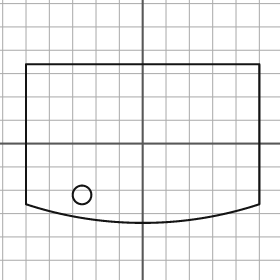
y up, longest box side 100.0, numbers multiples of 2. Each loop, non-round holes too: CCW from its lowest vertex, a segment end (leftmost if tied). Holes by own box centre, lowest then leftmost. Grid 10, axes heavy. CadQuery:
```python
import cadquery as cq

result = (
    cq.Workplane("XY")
    .moveTo(-50.0, -26.0)
    .threePointArc((0.0, -34.0), (50.0, -26.0))
    .lineTo(50.0, 34.0)
    .lineTo(-50.0, 34.0)
    .close()
    .moveTo(-26.0, -22.0)
    .circle(4.0)
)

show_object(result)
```